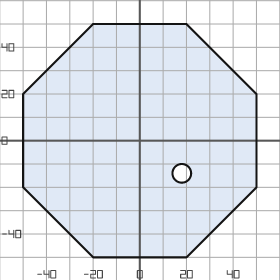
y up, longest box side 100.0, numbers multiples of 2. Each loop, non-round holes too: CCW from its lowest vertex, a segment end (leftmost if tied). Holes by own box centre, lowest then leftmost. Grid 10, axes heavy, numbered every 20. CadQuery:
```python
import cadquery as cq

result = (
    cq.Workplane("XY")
    .moveTo(-20.0, -50.0)
    .lineTo(20.0, -50.0)
    .lineTo(50.0, -20.0)
    .lineTo(50.0, 20.0)
    .lineTo(20.0, 50.0)
    .lineTo(-20.0, 50.0)
    .lineTo(-50.0, 20.0)
    .lineTo(-50.0, -20.0)
    .close()
    .moveTo(18.0, -14.0)
    .circle(4.0)
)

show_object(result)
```